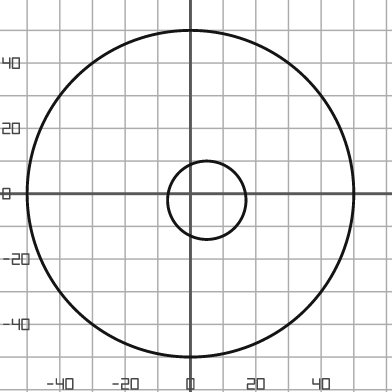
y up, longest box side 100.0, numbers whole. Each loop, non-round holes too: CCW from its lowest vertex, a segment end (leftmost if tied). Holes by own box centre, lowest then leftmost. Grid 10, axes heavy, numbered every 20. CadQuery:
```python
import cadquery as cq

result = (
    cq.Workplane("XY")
    .moveTo(0.0, 0.0)
    .circle(50.0)
    .moveTo(5.0, -2.0)
    .circle(12.0)
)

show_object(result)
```